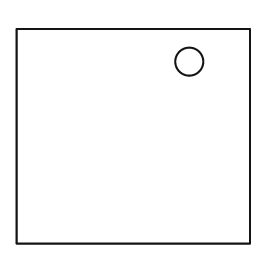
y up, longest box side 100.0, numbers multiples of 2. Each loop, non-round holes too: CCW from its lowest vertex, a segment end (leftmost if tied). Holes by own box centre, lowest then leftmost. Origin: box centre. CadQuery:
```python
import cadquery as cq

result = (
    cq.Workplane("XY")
    .moveTo(-50.0, -46.0)
    .lineTo(50.0, -46.0)
    .lineTo(50.0, 46.0)
    .lineTo(-50.0, 46.0)
    .close()
    .moveTo(24.0, 32.0)
    .circle(6.0)
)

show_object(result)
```